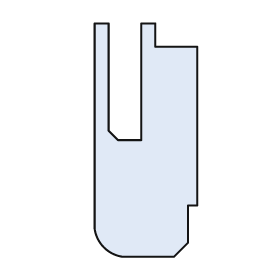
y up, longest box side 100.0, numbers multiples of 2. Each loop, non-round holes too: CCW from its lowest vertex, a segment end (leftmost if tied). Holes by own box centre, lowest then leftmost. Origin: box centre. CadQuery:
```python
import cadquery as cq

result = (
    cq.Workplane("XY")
    .moveTo(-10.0, -50.0)
    .lineTo(12.0, -50.0)
    .lineTo(18.0, -44.0)
    .lineTo(18.0, -28.0)
    .lineTo(22.0, -28.0)
    .lineTo(22.0, 40.0)
    .lineTo(4.0, 40.0)
    .lineTo(4.0, 50.0)
    .lineTo(-2.0, 50.0)
    .lineTo(-2.0, 0.0)
    .lineTo(-12.0, 0.0)
    .lineTo(-16.0, 4.0)
    .lineTo(-16.0, 50.0)
    .lineTo(-22.0, 50.0)
    .lineTo(-22.0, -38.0)
    .threePointArc((-18.0, -46.0), (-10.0, -50.0))
    .close()
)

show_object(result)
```